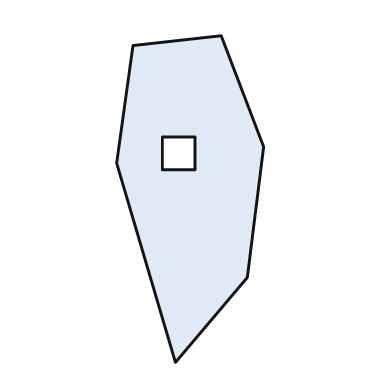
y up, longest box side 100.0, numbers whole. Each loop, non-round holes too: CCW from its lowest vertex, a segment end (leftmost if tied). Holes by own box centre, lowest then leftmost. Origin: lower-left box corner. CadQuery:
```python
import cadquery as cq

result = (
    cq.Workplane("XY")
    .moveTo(18.0, 0.0)
    .lineTo(40.0, 26.0)
    .lineTo(45.0, 66.0)
    .lineTo(32.0, 100.0)
    .lineTo(5.0, 97.0)
    .lineTo(0.0, 61.0)
    .close()
    .moveTo(14.0, 59.0)
    .lineTo(24.0, 59.0)
    .lineTo(24.0, 69.0)
    .lineTo(14.0, 69.0)
    .close()
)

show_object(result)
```